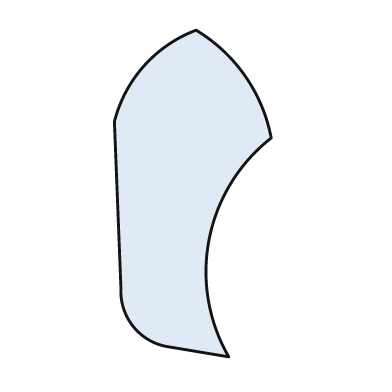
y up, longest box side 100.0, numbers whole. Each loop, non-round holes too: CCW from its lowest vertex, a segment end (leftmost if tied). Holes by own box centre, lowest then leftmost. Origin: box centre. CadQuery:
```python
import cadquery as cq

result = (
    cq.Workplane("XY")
    .moveTo(11.0, -50.0)
    .threePointArc((5.0, -14.0), (24.0, 17.0))
    .threePointArc((16.0, 36.0), (1.0, 50.0))
    .threePointArc((-15.0, 39.0), (-24.0, 22.0))
    .lineTo(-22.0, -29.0)
    .threePointArc((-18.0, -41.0), (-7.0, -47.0))
    .close()
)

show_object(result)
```